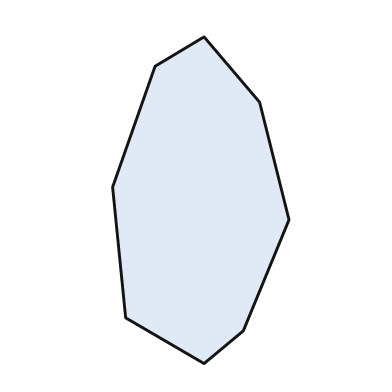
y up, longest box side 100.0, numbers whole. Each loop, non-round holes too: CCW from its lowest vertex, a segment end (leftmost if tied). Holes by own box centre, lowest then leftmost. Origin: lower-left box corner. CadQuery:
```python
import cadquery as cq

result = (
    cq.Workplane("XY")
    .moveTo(28.0, 0.0)
    .lineTo(40.0, 10.0)
    .lineTo(54.0, 44.0)
    .lineTo(45.0, 80.0)
    .lineTo(28.0, 100.0)
    .lineTo(13.0, 91.0)
    .lineTo(0.0, 54.0)
    .lineTo(4.0, 14.0)
    .close()
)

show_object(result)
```